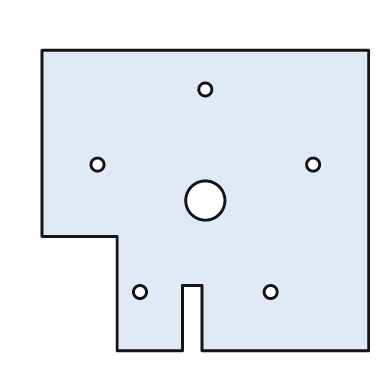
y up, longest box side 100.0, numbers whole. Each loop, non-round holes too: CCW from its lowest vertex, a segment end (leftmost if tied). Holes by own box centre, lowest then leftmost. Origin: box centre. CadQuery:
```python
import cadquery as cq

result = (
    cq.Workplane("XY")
    .moveTo(-27.0, -46.0)
    .lineTo(-7.0, -46.0)
    .lineTo(-7.0, -26.0)
    .lineTo(-1.0, -26.0)
    .lineTo(-1.0, -46.0)
    .lineTo(50.0, -46.0)
    .lineTo(50.0, 46.0)
    .lineTo(-50.0, 46.0)
    .lineTo(-50.0, -11.0)
    .lineTo(-27.0, -11.0)
    .close()
    .moveTo(-20.0, -28.0)
    .circle(2.0)
    .moveTo(20.0, -28.0)
    .circle(2.0)
    .moveTo(0.0, 0.0)
    .circle(6.0)
    .moveTo(-33.0, 11.0)
    .circle(2.0)
    .moveTo(33.0, 11.0)
    .circle(2.0)
    .moveTo(0.0, 34.0)
    .circle(2.0)
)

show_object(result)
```